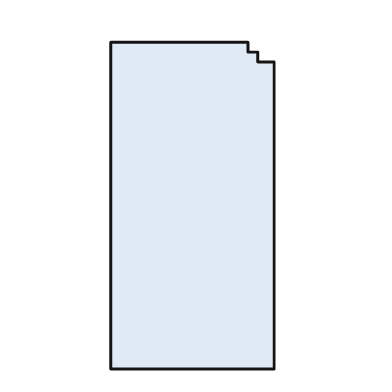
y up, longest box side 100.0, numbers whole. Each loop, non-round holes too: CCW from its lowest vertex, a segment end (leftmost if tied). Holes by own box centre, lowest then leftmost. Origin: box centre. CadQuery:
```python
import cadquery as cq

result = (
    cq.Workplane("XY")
    .moveTo(-25.0, -50.0)
    .lineTo(25.0, -50.0)
    .lineTo(25.0, 44.0)
    .lineTo(20.0, 44.0)
    .lineTo(20.0, 47.0)
    .lineTo(17.0, 47.0)
    .lineTo(17.0, 50.0)
    .lineTo(-25.0, 50.0)
    .close()
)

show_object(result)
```